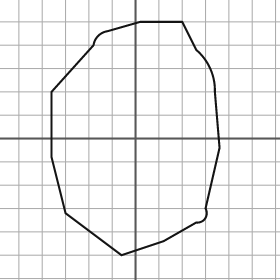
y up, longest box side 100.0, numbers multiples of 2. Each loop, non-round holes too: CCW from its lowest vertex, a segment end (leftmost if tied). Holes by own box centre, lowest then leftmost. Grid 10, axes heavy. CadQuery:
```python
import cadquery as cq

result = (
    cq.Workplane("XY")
    .moveTo(-6.0, -50.0)
    .lineTo(12.0, -44.0)
    .lineTo(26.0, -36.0)
    .threePointArc((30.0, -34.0), (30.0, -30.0))
    .lineTo(36.0, -4.0)
    .lineTo(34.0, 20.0)
    .threePointArc((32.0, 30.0), (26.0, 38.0))
    .lineTo(20.0, 50.0)
    .lineTo(2.0, 50.0)
    .lineTo(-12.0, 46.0)
    .threePointArc((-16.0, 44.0), (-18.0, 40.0))
    .lineTo(-36.0, 20.0)
    .lineTo(-36.0, -8.0)
    .lineTo(-30.0, -32.0)
    .close()
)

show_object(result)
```